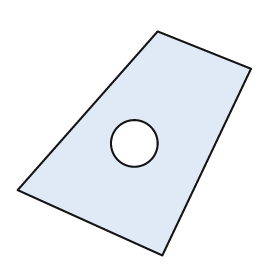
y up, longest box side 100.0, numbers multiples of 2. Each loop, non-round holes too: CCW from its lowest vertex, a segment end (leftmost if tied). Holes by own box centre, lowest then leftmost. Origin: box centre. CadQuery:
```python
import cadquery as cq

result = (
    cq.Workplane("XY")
    .moveTo(12.0, -48.0)
    .lineTo(50.0, 32.0)
    .lineTo(10.0, 48.0)
    .lineTo(-50.0, -20.0)
    .close()
    .moveTo(0.0, 0.0)
    .circle(10.0)
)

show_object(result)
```